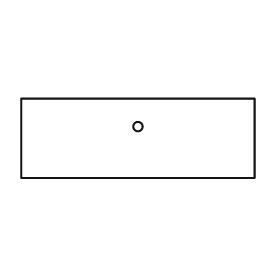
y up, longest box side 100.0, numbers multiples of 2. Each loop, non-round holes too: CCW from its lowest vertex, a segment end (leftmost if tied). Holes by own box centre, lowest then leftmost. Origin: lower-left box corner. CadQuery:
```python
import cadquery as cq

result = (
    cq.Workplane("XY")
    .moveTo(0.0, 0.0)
    .lineTo(100.0, 0.0)
    .lineTo(100.0, 34.0)
    .lineTo(0.0, 34.0)
    .close()
    .moveTo(50.0, 22.0)
    .circle(2.0)
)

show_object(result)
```